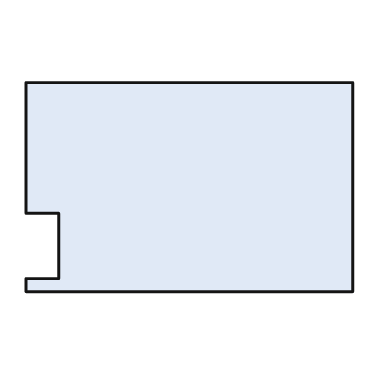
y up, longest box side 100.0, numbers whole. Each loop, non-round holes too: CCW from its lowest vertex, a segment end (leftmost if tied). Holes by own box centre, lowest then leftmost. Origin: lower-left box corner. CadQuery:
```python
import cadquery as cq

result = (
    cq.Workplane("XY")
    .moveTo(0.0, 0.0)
    .lineTo(100.0, 0.0)
    .lineTo(100.0, 64.0)
    .lineTo(0.0, 64.0)
    .lineTo(0.0, 24.0)
    .lineTo(10.0, 24.0)
    .lineTo(10.0, 4.0)
    .lineTo(0.0, 4.0)
    .close()
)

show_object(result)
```